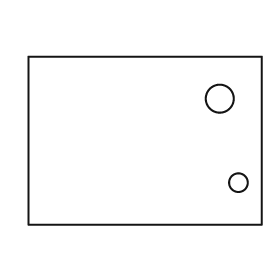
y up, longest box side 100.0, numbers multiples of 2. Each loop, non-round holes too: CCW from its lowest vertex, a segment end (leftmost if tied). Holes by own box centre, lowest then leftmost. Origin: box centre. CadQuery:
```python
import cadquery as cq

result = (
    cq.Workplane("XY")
    .moveTo(-50.0, -36.0)
    .lineTo(50.0, -36.0)
    .lineTo(50.0, 36.0)
    .lineTo(-50.0, 36.0)
    .close()
    .moveTo(40.0, -18.0)
    .circle(4.0)
    .moveTo(32.0, 18.0)
    .circle(6.0)
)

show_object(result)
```